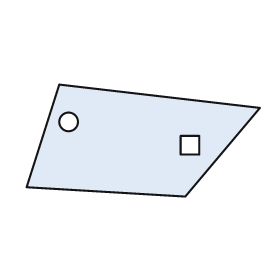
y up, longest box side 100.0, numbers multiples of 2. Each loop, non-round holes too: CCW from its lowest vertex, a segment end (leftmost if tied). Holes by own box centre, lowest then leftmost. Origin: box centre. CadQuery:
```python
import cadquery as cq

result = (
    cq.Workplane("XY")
    .moveTo(18.0, -24.0)
    .lineTo(50.0, 14.0)
    .lineTo(-36.0, 24.0)
    .lineTo(-50.0, -20.0)
    .close()
    .moveTo(16.0, -6.0)
    .lineTo(24.0, -6.0)
    .lineTo(24.0, 2.0)
    .lineTo(16.0, 2.0)
    .close()
    .moveTo(-32.0, 8.0)
    .circle(4.0)
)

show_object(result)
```